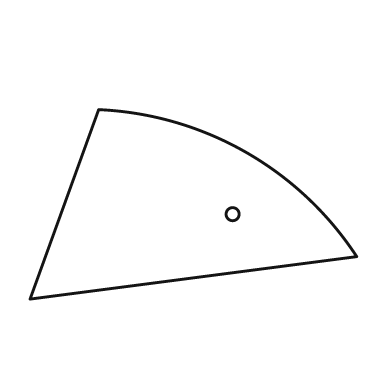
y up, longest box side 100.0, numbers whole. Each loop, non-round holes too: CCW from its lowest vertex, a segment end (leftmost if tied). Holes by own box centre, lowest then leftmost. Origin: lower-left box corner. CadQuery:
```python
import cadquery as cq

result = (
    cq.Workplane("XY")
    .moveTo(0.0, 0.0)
    .lineTo(100.0, 13.0)
    .threePointArc((66.0, 45.0), (21.0, 58.0))
    .close()
    .moveTo(62.0, 26.0)
    .circle(2.0)
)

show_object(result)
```